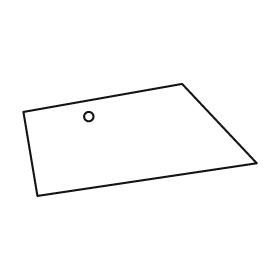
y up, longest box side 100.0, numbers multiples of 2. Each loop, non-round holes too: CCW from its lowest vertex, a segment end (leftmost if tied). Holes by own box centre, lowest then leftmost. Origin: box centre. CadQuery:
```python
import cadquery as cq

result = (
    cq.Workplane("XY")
    .moveTo(-44.0, -24.0)
    .lineTo(50.0, -10.0)
    .lineTo(18.0, 24.0)
    .lineTo(-50.0, 12.0)
    .close()
    .moveTo(-22.0, 10.0)
    .circle(2.0)
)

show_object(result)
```